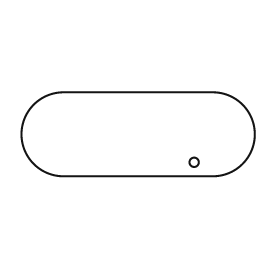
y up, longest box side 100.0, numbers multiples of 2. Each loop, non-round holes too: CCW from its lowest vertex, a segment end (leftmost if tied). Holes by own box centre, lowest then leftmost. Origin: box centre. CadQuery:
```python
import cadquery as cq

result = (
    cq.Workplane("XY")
    .moveTo(-32.0, -18.0)
    .lineTo(32.0, -18.0)
    .threePointArc((50.0, 0.0), (32.0, 18.0))
    .lineTo(-32.0, 18.0)
    .threePointArc((-50.0, 0.0), (-32.0, -18.0))
    .close()
    .moveTo(24.0, -12.0)
    .circle(2.0)
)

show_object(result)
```